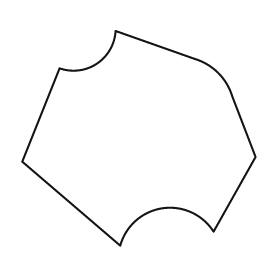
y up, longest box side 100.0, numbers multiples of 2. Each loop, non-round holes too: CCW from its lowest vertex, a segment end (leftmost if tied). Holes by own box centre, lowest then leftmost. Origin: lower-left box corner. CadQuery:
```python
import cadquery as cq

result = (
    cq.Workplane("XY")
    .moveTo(42.0, 0.0)
    .threePointArc((60.0, 16.0), (82.0, 6.0))
    .lineTo(100.0, 38.0)
    .lineTo(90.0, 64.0)
    .threePointArc((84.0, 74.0), (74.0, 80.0))
    .lineTo(40.0, 92.0)
    .threePointArc((32.0, 78.0), (16.0, 76.0))
    .lineTo(0.0, 36.0)
    .close()
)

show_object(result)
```